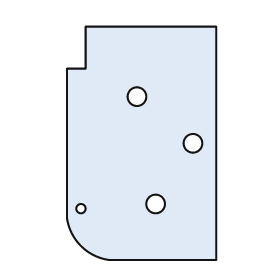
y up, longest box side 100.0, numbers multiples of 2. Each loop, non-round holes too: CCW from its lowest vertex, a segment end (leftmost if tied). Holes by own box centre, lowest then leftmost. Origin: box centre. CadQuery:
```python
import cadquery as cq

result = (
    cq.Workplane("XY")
    .moveTo(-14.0, -50.0)
    .lineTo(32.0, -50.0)
    .lineTo(32.0, 50.0)
    .lineTo(-24.0, 50.0)
    .lineTo(-24.0, 32.0)
    .lineTo(-32.0, 32.0)
    .lineTo(-32.0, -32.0)
    .threePointArc((-26.0, -44.0), (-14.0, -50.0))
    .close()
    .moveTo(-26.0, -28.0)
    .circle(2.0)
    .moveTo(6.0, -26.0)
    .circle(4.0)
    .moveTo(22.0, 0.0)
    .circle(4.0)
    .moveTo(-2.0, 20.0)
    .circle(4.0)
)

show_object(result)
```